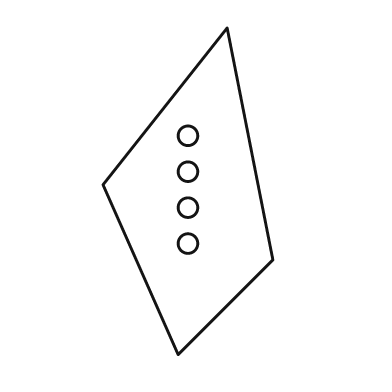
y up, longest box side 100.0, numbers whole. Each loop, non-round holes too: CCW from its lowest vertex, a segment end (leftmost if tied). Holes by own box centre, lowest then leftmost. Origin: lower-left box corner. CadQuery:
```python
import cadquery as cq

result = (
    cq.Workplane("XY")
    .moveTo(23.0, 0.0)
    .lineTo(52.0, 29.0)
    .lineTo(38.0, 100.0)
    .lineTo(0.0, 52.0)
    .close()
    .moveTo(26.0, 34.0)
    .circle(3.0)
    .moveTo(26.0, 45.0)
    .circle(3.0)
    .moveTo(26.0, 56.0)
    .circle(3.0)
    .moveTo(26.0, 67.0)
    .circle(3.0)
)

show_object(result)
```